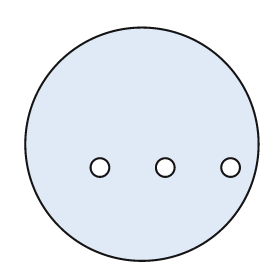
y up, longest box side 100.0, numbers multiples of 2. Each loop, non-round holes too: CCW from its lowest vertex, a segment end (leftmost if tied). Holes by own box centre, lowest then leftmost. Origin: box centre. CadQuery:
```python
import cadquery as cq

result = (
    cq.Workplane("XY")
    .moveTo(0.0, 0.0)
    .circle(50.0)
    .moveTo(-18.0, -10.0)
    .circle(4.0)
    .moveTo(10.0, -10.0)
    .circle(4.0)
    .moveTo(38.0, -10.0)
    .circle(4.0)
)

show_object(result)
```